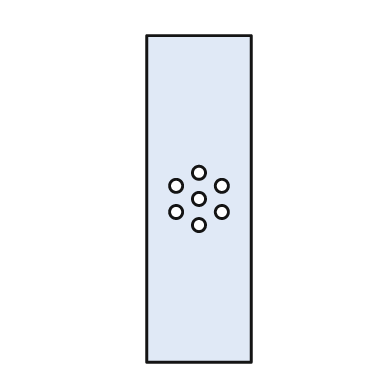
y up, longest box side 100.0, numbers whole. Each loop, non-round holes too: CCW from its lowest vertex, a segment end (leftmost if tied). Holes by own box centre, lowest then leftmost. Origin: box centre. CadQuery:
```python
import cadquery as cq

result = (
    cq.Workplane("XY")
    .moveTo(-16.0, -50.0)
    .lineTo(16.0, -50.0)
    .lineTo(16.0, 50.0)
    .lineTo(-16.0, 50.0)
    .close()
    .moveTo(0.0, -8.0)
    .circle(2.0)
    .moveTo(-7.0, -4.0)
    .circle(2.0)
    .moveTo(7.0, -4.0)
    .circle(2.0)
    .moveTo(0.0, 0.0)
    .circle(2.0)
    .moveTo(-7.0, 4.0)
    .circle(2.0)
    .moveTo(7.0, 4.0)
    .circle(2.0)
    .moveTo(0.0, 8.0)
    .circle(2.0)
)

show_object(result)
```